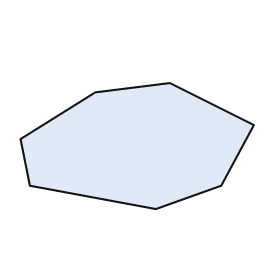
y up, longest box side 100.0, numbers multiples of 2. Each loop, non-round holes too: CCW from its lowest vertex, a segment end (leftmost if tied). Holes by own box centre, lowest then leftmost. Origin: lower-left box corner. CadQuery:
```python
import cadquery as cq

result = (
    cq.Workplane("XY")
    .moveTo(58.0, 0.0)
    .lineTo(86.0, 10.0)
    .lineTo(100.0, 36.0)
    .lineTo(64.0, 54.0)
    .lineTo(32.0, 50.0)
    .lineTo(0.0, 30.0)
    .lineTo(4.0, 10.0)
    .close()
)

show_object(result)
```